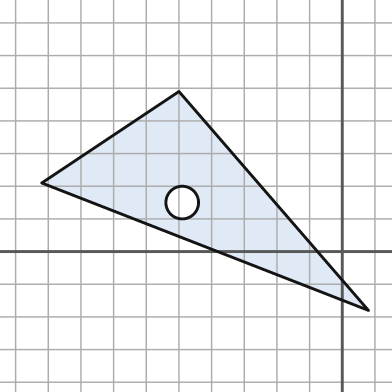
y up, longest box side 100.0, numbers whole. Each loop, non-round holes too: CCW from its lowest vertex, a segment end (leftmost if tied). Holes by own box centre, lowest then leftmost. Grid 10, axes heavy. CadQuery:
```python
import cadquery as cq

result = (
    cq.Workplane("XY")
    .moveTo(8.0, -18.0)
    .lineTo(-50.0, 49.0)
    .lineTo(-92.0, 21.0)
    .close()
    .moveTo(-49.0, 15.0)
    .circle(5.0)
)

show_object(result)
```